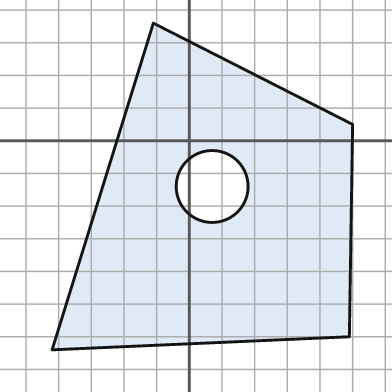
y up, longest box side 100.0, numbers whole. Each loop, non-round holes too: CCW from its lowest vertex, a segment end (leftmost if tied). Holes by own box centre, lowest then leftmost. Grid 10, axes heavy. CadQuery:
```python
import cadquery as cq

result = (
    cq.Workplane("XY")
    .moveTo(-42.0, -64.0)
    .lineTo(49.0, -60.0)
    .lineTo(50.0, 5.0)
    .lineTo(-11.0, 36.0)
    .close()
    .moveTo(7.0, -14.0)
    .circle(11.0)
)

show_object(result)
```